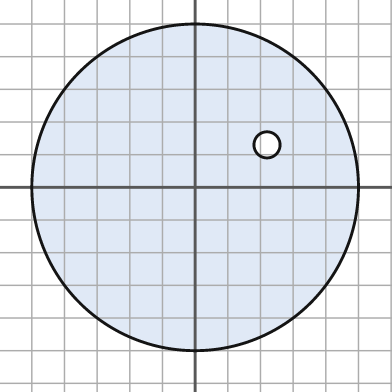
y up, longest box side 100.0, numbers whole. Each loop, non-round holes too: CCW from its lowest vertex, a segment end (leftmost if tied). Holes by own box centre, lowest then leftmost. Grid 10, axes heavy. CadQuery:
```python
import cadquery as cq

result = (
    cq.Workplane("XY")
    .moveTo(0.0, 0.0)
    .circle(50.0)
    .moveTo(22.0, 13.0)
    .circle(4.0)
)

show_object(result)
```